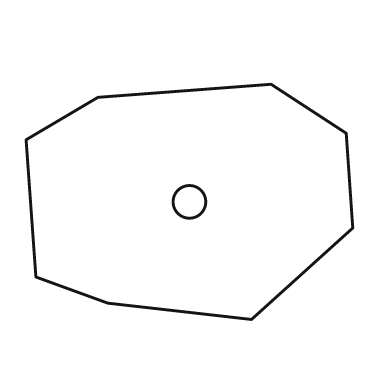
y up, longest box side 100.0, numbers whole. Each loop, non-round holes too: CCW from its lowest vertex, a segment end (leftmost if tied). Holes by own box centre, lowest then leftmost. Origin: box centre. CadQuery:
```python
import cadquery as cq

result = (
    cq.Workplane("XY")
    .moveTo(19.0, -36.0)
    .lineTo(50.0, -8.0)
    .lineTo(48.0, 21.0)
    .lineTo(25.0, 36.0)
    .lineTo(-28.0, 32.0)
    .lineTo(-50.0, 19.0)
    .lineTo(-47.0, -23.0)
    .lineTo(-25.0, -31.0)
    .close()
    .moveTo(0.0, 0.0)
    .circle(5.0)
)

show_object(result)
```